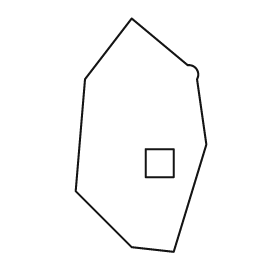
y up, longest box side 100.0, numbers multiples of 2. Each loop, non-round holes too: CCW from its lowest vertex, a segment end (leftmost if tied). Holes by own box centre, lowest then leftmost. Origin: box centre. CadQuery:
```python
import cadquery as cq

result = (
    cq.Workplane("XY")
    .moveTo(14.0, -50.0)
    .lineTo(28.0, -4.0)
    .lineTo(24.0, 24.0)
    .threePointArc((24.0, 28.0), (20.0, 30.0))
    .lineTo(-4.0, 50.0)
    .lineTo(-24.0, 24.0)
    .lineTo(-28.0, -24.0)
    .lineTo(-4.0, -48.0)
    .close()
    .moveTo(2.0, -18.0)
    .lineTo(14.0, -18.0)
    .lineTo(14.0, -6.0)
    .lineTo(2.0, -6.0)
    .close()
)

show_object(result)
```